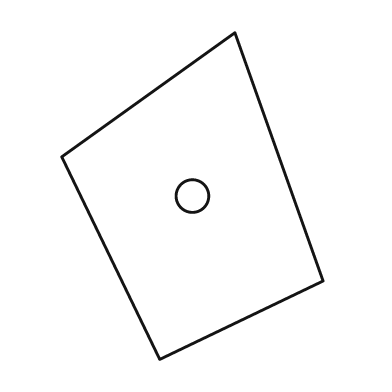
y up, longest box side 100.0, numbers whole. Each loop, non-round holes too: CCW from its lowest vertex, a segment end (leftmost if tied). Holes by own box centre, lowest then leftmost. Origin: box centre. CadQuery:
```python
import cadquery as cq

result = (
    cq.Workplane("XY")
    .moveTo(-10.0, -50.0)
    .lineTo(40.0, -26.0)
    .lineTo(13.0, 50.0)
    .lineTo(-40.0, 12.0)
    .close()
    .moveTo(0.0, 0.0)
    .circle(5.0)
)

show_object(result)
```